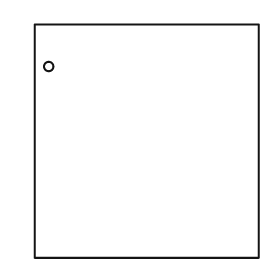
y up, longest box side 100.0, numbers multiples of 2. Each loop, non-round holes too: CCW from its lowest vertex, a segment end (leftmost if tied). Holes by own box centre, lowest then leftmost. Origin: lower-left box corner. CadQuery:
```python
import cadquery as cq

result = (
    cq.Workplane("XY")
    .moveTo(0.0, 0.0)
    .lineTo(96.0, 0.0)
    .lineTo(96.0, 100.0)
    .lineTo(0.0, 100.0)
    .close()
    .moveTo(6.0, 82.0)
    .circle(2.0)
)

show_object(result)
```